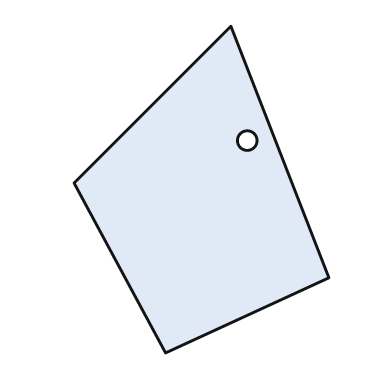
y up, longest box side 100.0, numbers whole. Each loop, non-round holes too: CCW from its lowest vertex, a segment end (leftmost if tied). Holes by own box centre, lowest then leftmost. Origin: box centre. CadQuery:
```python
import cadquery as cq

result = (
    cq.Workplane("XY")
    .moveTo(-11.0, -50.0)
    .lineTo(39.0, -27.0)
    .lineTo(9.0, 50.0)
    .lineTo(-39.0, 2.0)
    .close()
    .moveTo(14.0, 15.0)
    .circle(3.0)
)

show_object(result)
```